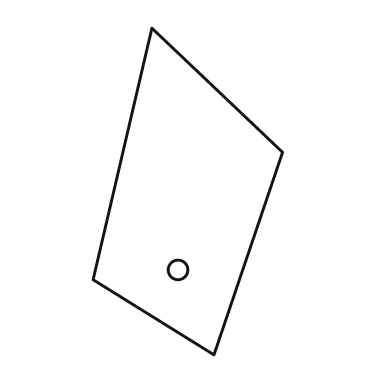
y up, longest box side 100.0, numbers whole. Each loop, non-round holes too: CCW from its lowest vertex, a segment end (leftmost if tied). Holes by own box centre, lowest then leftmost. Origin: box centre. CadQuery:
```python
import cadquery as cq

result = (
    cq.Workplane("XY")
    .moveTo(8.0, -50.0)
    .lineTo(29.0, 12.0)
    .lineTo(-11.0, 50.0)
    .lineTo(-29.0, -27.0)
    .close()
    .moveTo(-3.0, -24.0)
    .circle(3.0)
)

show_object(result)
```